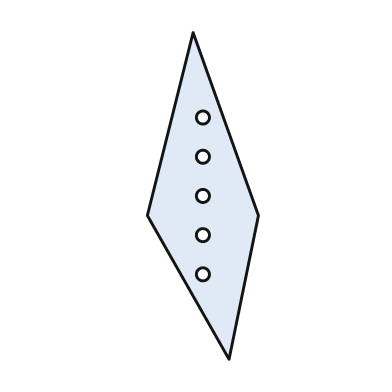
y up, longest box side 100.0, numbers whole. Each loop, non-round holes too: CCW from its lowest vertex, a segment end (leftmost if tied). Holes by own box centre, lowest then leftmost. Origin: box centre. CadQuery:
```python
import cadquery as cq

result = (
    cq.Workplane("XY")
    .moveTo(8.0, -50.0)
    .lineTo(17.0, -6.0)
    .lineTo(-3.0, 50.0)
    .lineTo(-17.0, -6.0)
    .close()
    .moveTo(0.0, -24.0)
    .circle(2.0)
    .moveTo(0.0, -12.0)
    .circle(2.0)
    .moveTo(0.0, 0.0)
    .circle(2.0)
    .moveTo(0.0, 12.0)
    .circle(2.0)
    .moveTo(0.0, 24.0)
    .circle(2.0)
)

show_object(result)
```